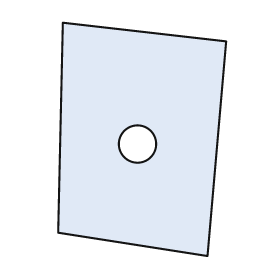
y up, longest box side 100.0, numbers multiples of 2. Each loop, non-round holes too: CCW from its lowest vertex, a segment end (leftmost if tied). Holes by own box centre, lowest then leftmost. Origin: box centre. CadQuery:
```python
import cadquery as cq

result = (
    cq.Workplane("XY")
    .moveTo(28.0, -50.0)
    .lineTo(36.0, 42.0)
    .lineTo(-34.0, 50.0)
    .lineTo(-36.0, -40.0)
    .close()
    .moveTo(-2.0, -2.0)
    .circle(8.0)
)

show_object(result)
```